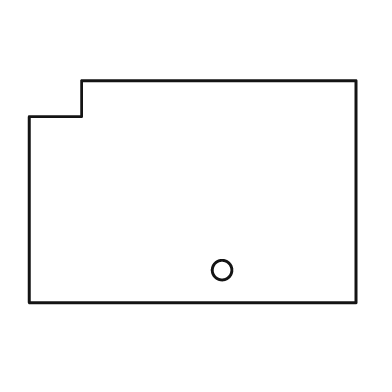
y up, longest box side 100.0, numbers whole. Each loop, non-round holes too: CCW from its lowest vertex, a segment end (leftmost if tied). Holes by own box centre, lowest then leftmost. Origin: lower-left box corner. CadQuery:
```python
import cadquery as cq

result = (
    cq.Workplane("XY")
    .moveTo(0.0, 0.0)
    .lineTo(100.0, 0.0)
    .lineTo(100.0, 68.0)
    .lineTo(16.0, 68.0)
    .lineTo(16.0, 57.0)
    .lineTo(0.0, 57.0)
    .close()
    .moveTo(59.0, 10.0)
    .circle(3.0)
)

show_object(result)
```